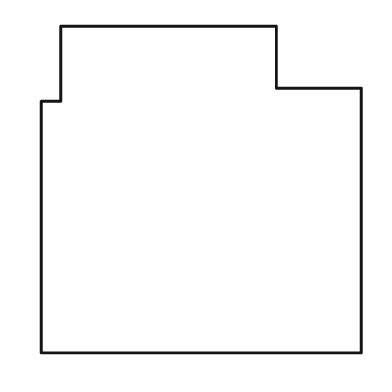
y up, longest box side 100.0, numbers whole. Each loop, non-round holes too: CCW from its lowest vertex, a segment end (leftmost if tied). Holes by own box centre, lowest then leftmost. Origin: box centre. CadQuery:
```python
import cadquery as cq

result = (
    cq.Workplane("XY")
    .moveTo(-49.0, -50.0)
    .lineTo(49.0, -50.0)
    .lineTo(49.0, 31.0)
    .lineTo(23.0, 31.0)
    .lineTo(23.0, 50.0)
    .lineTo(-43.0, 50.0)
    .lineTo(-43.0, 27.0)
    .lineTo(-49.0, 27.0)
    .close()
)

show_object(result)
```